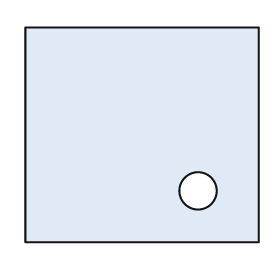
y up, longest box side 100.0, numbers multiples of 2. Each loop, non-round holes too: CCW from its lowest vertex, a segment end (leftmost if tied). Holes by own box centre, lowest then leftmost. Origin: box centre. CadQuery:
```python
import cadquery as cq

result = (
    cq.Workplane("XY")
    .moveTo(-50.0, -46.0)
    .lineTo(50.0, -46.0)
    .lineTo(50.0, 46.0)
    .lineTo(-50.0, 46.0)
    .close()
    .moveTo(24.0, -24.0)
    .circle(8.0)
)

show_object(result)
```